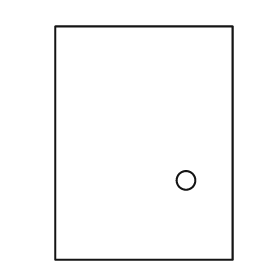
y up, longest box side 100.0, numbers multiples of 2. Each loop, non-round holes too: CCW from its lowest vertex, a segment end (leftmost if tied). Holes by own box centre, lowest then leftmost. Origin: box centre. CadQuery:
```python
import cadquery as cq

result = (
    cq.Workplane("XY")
    .moveTo(-38.0, -50.0)
    .lineTo(38.0, -50.0)
    .lineTo(38.0, 50.0)
    .lineTo(-38.0, 50.0)
    .close()
    .moveTo(18.0, -16.0)
    .circle(4.0)
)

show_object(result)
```